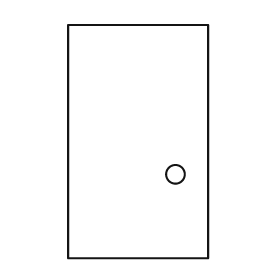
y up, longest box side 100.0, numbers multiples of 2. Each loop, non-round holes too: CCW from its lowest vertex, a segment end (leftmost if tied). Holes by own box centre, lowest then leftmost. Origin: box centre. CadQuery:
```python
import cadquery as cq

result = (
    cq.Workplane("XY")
    .moveTo(-30.0, -50.0)
    .lineTo(30.0, -50.0)
    .lineTo(30.0, 50.0)
    .lineTo(-30.0, 50.0)
    .close()
    .moveTo(16.0, -14.0)
    .circle(4.0)
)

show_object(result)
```